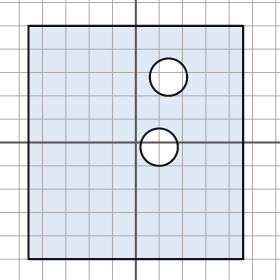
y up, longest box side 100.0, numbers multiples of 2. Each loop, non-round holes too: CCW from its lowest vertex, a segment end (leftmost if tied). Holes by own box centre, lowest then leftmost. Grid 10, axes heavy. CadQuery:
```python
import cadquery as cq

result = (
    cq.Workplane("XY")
    .moveTo(-46.0, -50.0)
    .lineTo(46.0, -50.0)
    .lineTo(46.0, 50.0)
    .lineTo(-46.0, 50.0)
    .close()
    .moveTo(10.0, -2.0)
    .circle(8.0)
    .moveTo(14.0, 28.0)
    .circle(8.0)
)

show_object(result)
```